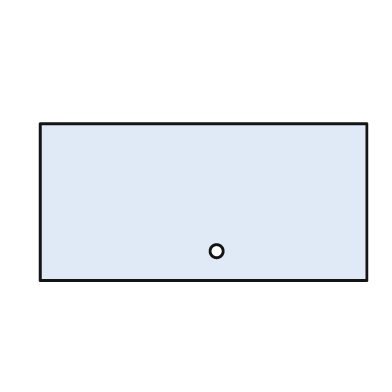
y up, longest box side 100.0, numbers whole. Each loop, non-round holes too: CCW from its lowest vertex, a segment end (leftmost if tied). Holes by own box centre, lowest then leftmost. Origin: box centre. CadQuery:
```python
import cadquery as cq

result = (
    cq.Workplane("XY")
    .moveTo(-50.0, -24.0)
    .lineTo(50.0, -24.0)
    .lineTo(50.0, 24.0)
    .lineTo(-50.0, 24.0)
    .close()
    .moveTo(4.0, -15.0)
    .circle(2.0)
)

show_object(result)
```